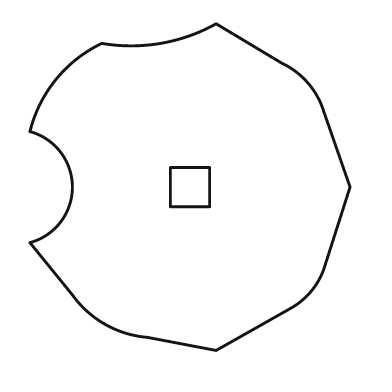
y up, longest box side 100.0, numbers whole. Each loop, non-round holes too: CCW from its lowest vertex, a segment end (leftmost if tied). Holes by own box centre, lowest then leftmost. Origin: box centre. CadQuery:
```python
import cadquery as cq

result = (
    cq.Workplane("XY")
    .moveTo(8.0, -50.0)
    .lineTo(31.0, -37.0)
    .threePointArc((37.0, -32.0), (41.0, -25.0))
    .lineTo(49.0, 0.0)
    .lineTo(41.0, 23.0)
    .threePointArc((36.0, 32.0), (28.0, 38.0))
    .lineTo(8.0, 50.0)
    .threePointArc((-9.0, 44.0), (-27.0, 44.0))
    .threePointArc((-41.0, 33.0), (-49.0, 17.0))
    .threePointArc((-36.0, 0.0), (-49.0, -17.0))
    .lineTo(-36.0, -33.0)
    .threePointArc((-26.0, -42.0), (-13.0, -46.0))
    .close()
    .moveTo(-6.0, -6.0)
    .lineTo(6.0, -6.0)
    .lineTo(6.0, 6.0)
    .lineTo(-6.0, 6.0)
    .close()
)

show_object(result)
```